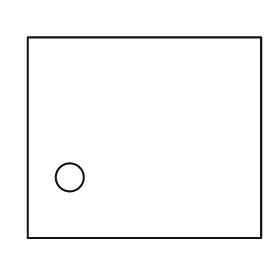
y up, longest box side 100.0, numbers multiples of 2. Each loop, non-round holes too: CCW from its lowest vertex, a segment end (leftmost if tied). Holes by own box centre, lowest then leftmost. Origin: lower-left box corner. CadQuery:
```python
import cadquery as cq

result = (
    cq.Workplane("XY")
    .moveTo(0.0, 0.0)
    .lineTo(100.0, 0.0)
    .lineTo(100.0, 86.0)
    .lineTo(0.0, 86.0)
    .close()
    .moveTo(18.0, 26.0)
    .circle(6.0)
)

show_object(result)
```